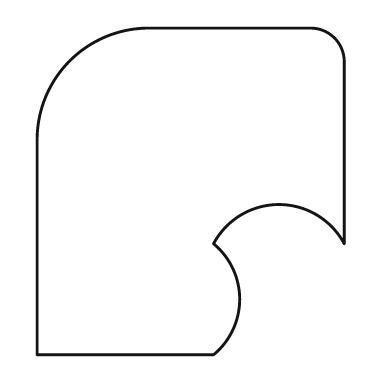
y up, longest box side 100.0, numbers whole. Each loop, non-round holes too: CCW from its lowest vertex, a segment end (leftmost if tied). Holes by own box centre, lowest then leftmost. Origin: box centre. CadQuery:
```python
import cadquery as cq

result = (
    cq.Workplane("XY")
    .moveTo(-47.0, -50.0)
    .lineTo(7.0, -50.0)
    .threePointArc((15.0, -33.0), (7.0, -16.0))
    .threePointArc((27.0, -4.0), (47.0, -16.0))
    .lineTo(47.0, 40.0)
    .threePointArc((44.0, 47.0), (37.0, 50.0))
    .lineTo(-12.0, 50.0)
    .threePointArc((-37.0, 40.0), (-47.0, 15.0))
    .close()
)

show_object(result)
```